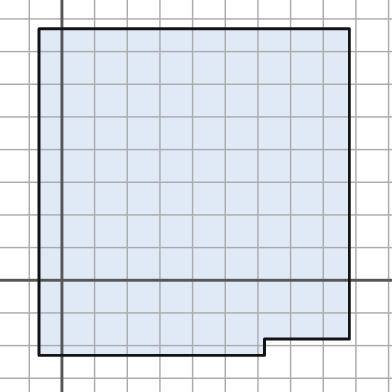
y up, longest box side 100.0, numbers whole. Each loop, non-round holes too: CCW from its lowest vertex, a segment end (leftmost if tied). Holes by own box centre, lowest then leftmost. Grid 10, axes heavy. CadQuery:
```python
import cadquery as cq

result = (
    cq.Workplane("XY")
    .moveTo(-7.0, -23.0)
    .lineTo(62.0, -23.0)
    .lineTo(62.0, -18.0)
    .lineTo(88.0, -18.0)
    .lineTo(88.0, 77.0)
    .lineTo(-7.0, 77.0)
    .close()
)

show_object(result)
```